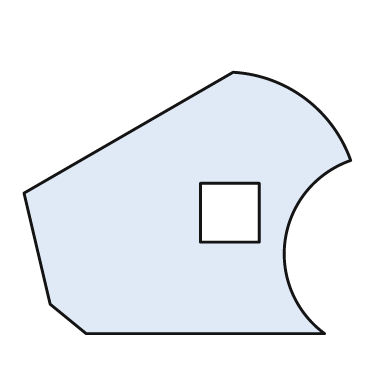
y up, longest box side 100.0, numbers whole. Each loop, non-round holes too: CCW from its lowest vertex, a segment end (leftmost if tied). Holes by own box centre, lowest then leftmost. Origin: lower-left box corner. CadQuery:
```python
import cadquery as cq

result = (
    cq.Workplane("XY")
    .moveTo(19.0, 0.0)
    .lineTo(92.0, 0.0)
    .threePointArc((80.0, 29.0), (100.0, 53.0))
    .threePointArc((86.0, 72.0), (64.0, 80.0))
    .lineTo(0.0, 43.0)
    .lineTo(8.0, 9.0)
    .close()
    .moveTo(54.0, 28.0)
    .lineTo(72.0, 28.0)
    .lineTo(72.0, 46.0)
    .lineTo(54.0, 46.0)
    .close()
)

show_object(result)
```